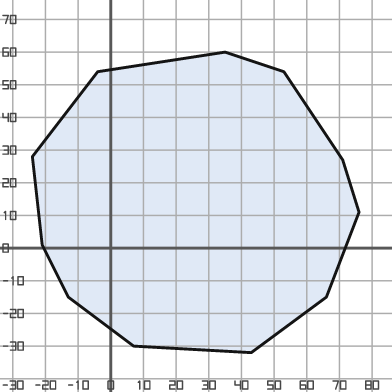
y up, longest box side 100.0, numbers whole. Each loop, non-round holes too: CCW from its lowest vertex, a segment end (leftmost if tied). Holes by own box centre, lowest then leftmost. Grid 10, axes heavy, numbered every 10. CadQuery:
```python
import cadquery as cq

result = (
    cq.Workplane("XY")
    .moveTo(43.0, -32.0)
    .lineTo(66.0, -15.0)
    .lineTo(76.0, 11.0)
    .lineTo(71.0, 27.0)
    .lineTo(53.0, 54.0)
    .lineTo(35.0, 60.0)
    .lineTo(-4.0, 54.0)
    .lineTo(-24.0, 28.0)
    .lineTo(-21.0, 1.0)
    .lineTo(-13.0, -15.0)
    .lineTo(7.0, -30.0)
    .close()
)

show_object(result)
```